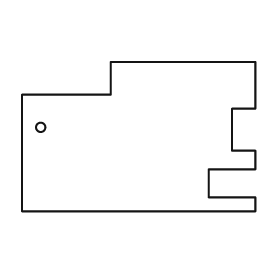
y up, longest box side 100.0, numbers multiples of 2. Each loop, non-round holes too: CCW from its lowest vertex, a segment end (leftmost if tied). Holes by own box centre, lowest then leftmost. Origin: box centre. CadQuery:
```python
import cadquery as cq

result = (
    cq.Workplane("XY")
    .moveTo(-50.0, -32.0)
    .lineTo(50.0, -32.0)
    .lineTo(50.0, -26.0)
    .lineTo(30.0, -26.0)
    .lineTo(30.0, -14.0)
    .lineTo(50.0, -14.0)
    .lineTo(50.0, -6.0)
    .lineTo(40.0, -6.0)
    .lineTo(40.0, 12.0)
    .lineTo(50.0, 12.0)
    .lineTo(50.0, 32.0)
    .lineTo(-12.0, 32.0)
    .lineTo(-12.0, 18.0)
    .lineTo(-50.0, 18.0)
    .close()
    .moveTo(-42.0, 4.0)
    .circle(2.0)
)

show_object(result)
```